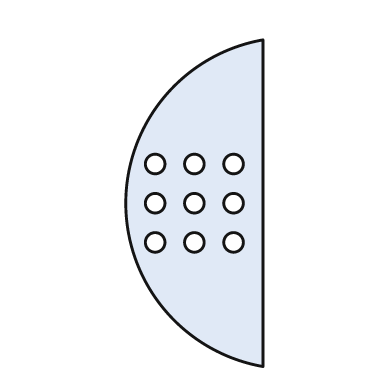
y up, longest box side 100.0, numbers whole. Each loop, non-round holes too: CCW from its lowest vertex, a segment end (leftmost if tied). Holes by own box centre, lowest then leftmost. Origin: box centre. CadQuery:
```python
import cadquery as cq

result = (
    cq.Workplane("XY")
    .moveTo(21.0, -50.0)
    .lineTo(21.0, 50.0)
    .threePointArc((-21.0, 0.0), (21.0, -50.0))
    .close()
    .moveTo(-12.0, -12.0)
    .circle(3.0)
    .moveTo(0.0, -12.0)
    .circle(3.0)
    .moveTo(12.0, -12.0)
    .circle(3.0)
    .moveTo(-12.0, 0.0)
    .circle(3.0)
    .moveTo(0.0, 0.0)
    .circle(3.0)
    .moveTo(12.0, 0.0)
    .circle(3.0)
    .moveTo(-12.0, 12.0)
    .circle(3.0)
    .moveTo(0.0, 12.0)
    .circle(3.0)
    .moveTo(12.0, 12.0)
    .circle(3.0)
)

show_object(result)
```